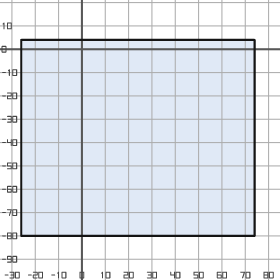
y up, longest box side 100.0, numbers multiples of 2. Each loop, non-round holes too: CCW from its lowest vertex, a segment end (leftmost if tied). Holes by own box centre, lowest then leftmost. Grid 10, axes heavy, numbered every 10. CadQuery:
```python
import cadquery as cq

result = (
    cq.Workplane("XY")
    .moveTo(-26.0, -80.0)
    .lineTo(74.0, -80.0)
    .lineTo(74.0, 4.0)
    .lineTo(-26.0, 4.0)
    .close()
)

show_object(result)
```